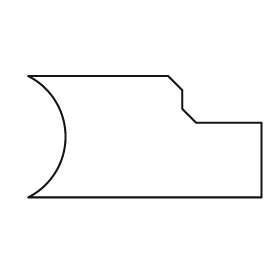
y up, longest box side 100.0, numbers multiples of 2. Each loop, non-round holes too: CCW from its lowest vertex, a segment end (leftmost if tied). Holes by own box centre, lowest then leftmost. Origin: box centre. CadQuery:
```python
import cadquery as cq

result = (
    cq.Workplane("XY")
    .moveTo(-50.0, -26.0)
    .lineTo(50.0, -26.0)
    .lineTo(50.0, 6.0)
    .lineTo(22.0, 6.0)
    .lineTo(16.0, 12.0)
    .lineTo(16.0, 20.0)
    .lineTo(10.0, 26.0)
    .lineTo(-50.0, 26.0)
    .threePointArc((-34.0, 0.0), (-50.0, -26.0))
    .close()
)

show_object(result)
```